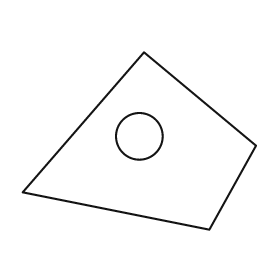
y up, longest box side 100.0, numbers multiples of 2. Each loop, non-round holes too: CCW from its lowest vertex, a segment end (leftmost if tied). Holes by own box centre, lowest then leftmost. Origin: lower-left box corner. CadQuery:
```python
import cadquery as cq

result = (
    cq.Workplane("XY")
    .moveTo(80.0, 0.0)
    .lineTo(100.0, 36.0)
    .lineTo(52.0, 76.0)
    .lineTo(0.0, 16.0)
    .close()
    .moveTo(50.0, 40.0)
    .circle(10.0)
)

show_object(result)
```